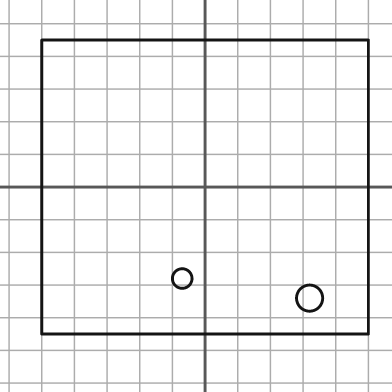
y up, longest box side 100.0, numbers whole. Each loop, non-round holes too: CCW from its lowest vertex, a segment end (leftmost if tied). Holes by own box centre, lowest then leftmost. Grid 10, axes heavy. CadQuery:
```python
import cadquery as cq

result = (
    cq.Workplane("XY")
    .moveTo(-50.0, -45.0)
    .lineTo(50.0, -45.0)
    .lineTo(50.0, 45.0)
    .lineTo(-50.0, 45.0)
    .close()
    .moveTo(32.0, -34.0)
    .circle(4.0)
    .moveTo(-7.0, -28.0)
    .circle(3.0)
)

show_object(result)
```